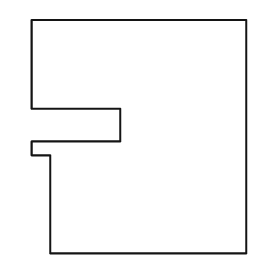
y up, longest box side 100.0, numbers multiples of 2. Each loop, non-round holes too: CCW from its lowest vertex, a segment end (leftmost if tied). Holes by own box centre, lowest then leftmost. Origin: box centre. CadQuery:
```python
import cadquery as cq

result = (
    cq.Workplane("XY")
    .moveTo(-38.0, -50.0)
    .lineTo(46.0, -50.0)
    .lineTo(46.0, 50.0)
    .lineTo(-46.0, 50.0)
    .lineTo(-46.0, 12.0)
    .lineTo(-8.0, 12.0)
    .lineTo(-8.0, -2.0)
    .lineTo(-46.0, -2.0)
    .lineTo(-46.0, -8.0)
    .lineTo(-38.0, -8.0)
    .close()
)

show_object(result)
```